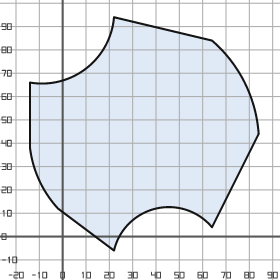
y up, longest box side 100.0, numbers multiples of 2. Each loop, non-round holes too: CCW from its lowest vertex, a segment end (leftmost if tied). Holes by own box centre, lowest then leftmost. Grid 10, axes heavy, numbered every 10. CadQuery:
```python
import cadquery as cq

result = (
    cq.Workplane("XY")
    .moveTo(22.0, -6.0)
    .threePointArc((40.0, 12.0), (64.0, 4.0))
    .lineTo(84.0, 44.0)
    .threePointArc((78.0, 66.0), (64.0, 84.0))
    .lineTo(22.0, 94.0)
    .threePointArc((10.0, 72.0), (-14.0, 66.0))
    .lineTo(-14.0, 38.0)
    .threePointArc((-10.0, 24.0), (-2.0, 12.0))
    .close()
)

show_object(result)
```